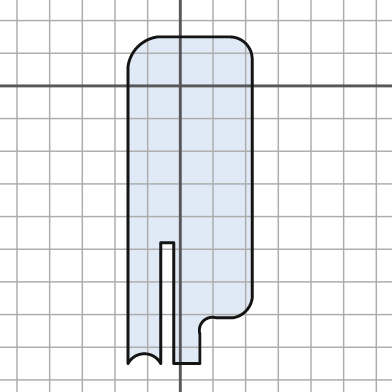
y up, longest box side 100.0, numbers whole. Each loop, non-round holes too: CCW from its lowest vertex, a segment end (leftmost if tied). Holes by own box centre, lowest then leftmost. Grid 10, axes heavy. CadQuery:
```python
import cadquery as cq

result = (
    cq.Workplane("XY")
    .moveTo(-16.0, -85.0)
    .threePointArc((-11.0, -82.0), (-6.0, -85.0))
    .lineTo(-6.0, -48.0)
    .lineTo(-2.0, -48.0)
    .lineTo(-2.0, -85.0)
    .lineTo(6.0, -85.0)
    .lineTo(6.0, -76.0)
    .threePointArc((7.0, -72.0), (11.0, -71.0))
    .lineTo(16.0, -71.0)
    .threePointArc((20.0, -69.0), (22.0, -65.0))
    .lineTo(22.0, 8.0)
    .threePointArc((20.0, 13.0), (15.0, 15.0))
    .lineTo(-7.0, 15.0)
    .threePointArc((-13.0, 12.0), (-16.0, 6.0))
    .close()
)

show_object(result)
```